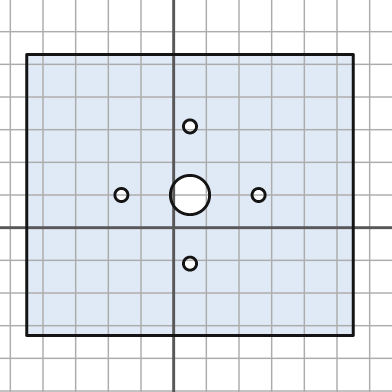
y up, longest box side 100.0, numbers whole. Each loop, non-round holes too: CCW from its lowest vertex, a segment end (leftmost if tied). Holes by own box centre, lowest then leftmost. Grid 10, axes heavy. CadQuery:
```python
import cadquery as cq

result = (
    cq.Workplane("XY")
    .moveTo(-45.0, -33.0)
    .lineTo(55.0, -33.0)
    .lineTo(55.0, 53.0)
    .lineTo(-45.0, 53.0)
    .close()
    .moveTo(5.0, -11.0)
    .circle(2.0)
    .moveTo(-16.0, 10.0)
    .circle(2.0)
    .moveTo(5.0, 10.0)
    .circle(6.0)
    .moveTo(26.0, 10.0)
    .circle(2.0)
    .moveTo(5.0, 31.0)
    .circle(2.0)
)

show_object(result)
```